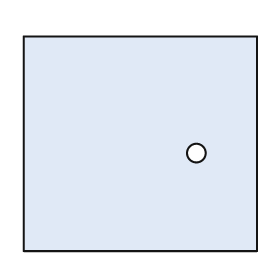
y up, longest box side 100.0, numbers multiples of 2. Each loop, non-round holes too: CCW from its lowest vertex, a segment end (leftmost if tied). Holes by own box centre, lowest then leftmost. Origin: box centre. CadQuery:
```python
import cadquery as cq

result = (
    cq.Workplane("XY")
    .moveTo(-50.0, -46.0)
    .lineTo(50.0, -46.0)
    .lineTo(50.0, 46.0)
    .lineTo(-50.0, 46.0)
    .close()
    .moveTo(24.0, -4.0)
    .circle(4.0)
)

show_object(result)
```